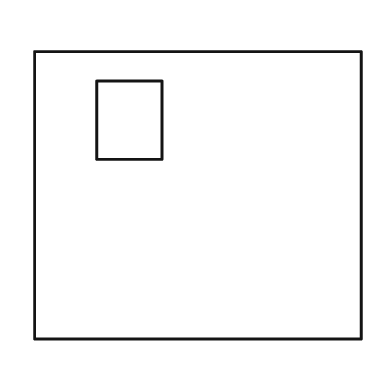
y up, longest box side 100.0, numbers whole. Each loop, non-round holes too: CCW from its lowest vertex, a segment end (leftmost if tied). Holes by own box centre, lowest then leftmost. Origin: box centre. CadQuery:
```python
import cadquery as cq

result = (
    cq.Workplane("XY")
    .moveTo(-50.0, -44.0)
    .lineTo(50.0, -44.0)
    .lineTo(50.0, 44.0)
    .lineTo(-50.0, 44.0)
    .close()
    .moveTo(-31.0, 11.0)
    .lineTo(-11.0, 11.0)
    .lineTo(-11.0, 35.0)
    .lineTo(-31.0, 35.0)
    .close()
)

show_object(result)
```